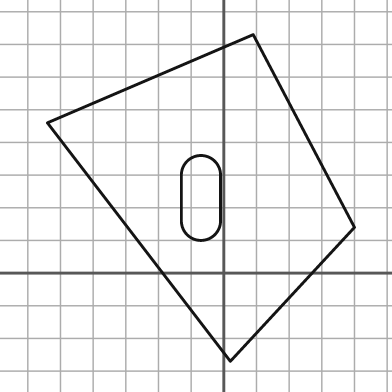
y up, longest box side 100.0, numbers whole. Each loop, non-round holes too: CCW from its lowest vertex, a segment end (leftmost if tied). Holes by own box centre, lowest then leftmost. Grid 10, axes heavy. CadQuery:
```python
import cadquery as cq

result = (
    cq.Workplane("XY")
    .moveTo(2.0, -27.0)
    .lineTo(40.0, 14.0)
    .lineTo(9.0, 73.0)
    .lineTo(-54.0, 46.0)
    .close()
    .moveTo(-13.0, 16.0)
    .threePointArc((-7.0, 10.0), (-1.0, 16.0))
    .lineTo(-1.0, 30.0)
    .threePointArc((-7.0, 36.0), (-13.0, 30.0))
    .close()
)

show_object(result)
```